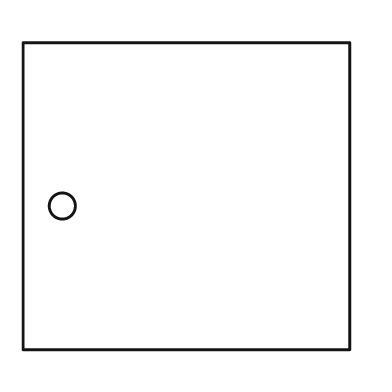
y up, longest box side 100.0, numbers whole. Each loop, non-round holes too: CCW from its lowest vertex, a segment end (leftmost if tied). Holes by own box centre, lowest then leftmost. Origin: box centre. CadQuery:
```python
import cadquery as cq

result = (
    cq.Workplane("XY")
    .moveTo(-50.0, -47.0)
    .lineTo(50.0, -47.0)
    .lineTo(50.0, 47.0)
    .lineTo(-50.0, 47.0)
    .close()
    .moveTo(-38.0, -3.0)
    .circle(4.0)
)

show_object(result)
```